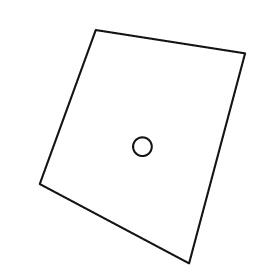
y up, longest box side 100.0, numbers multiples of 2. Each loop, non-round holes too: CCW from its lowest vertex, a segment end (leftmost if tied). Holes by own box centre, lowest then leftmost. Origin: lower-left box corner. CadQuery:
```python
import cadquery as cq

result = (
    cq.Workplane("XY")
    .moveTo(64.0, 0.0)
    .lineTo(88.0, 90.0)
    .lineTo(24.0, 100.0)
    .lineTo(0.0, 34.0)
    .close()
    .moveTo(44.0, 50.0)
    .circle(4.0)
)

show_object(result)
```